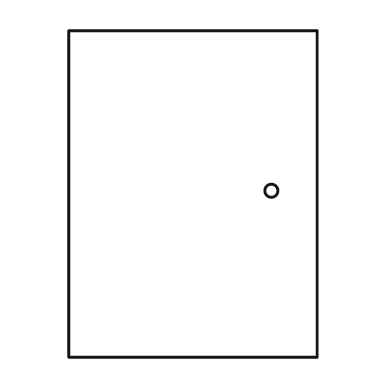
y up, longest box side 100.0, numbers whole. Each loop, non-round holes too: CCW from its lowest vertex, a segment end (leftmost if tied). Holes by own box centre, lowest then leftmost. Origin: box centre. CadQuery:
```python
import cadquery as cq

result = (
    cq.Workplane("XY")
    .moveTo(-38.0, -50.0)
    .lineTo(38.0, -50.0)
    .lineTo(38.0, 50.0)
    .lineTo(-38.0, 50.0)
    .close()
    .moveTo(24.0, 1.0)
    .circle(2.0)
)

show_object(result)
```